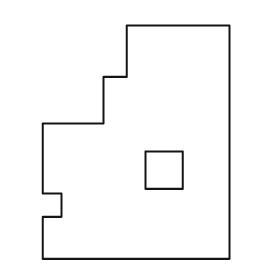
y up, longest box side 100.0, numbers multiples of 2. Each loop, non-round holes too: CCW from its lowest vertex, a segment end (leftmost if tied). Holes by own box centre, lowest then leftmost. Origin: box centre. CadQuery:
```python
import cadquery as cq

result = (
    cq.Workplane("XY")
    .moveTo(-40.0, -50.0)
    .lineTo(40.0, -50.0)
    .lineTo(40.0, 50.0)
    .lineTo(-4.0, 50.0)
    .lineTo(-4.0, 28.0)
    .lineTo(-14.0, 28.0)
    .lineTo(-14.0, 8.0)
    .lineTo(-40.0, 8.0)
    .lineTo(-40.0, -22.0)
    .lineTo(-32.0, -22.0)
    .lineTo(-32.0, -32.0)
    .lineTo(-40.0, -32.0)
    .close()
    .moveTo(4.0, -20.0)
    .lineTo(20.0, -20.0)
    .lineTo(20.0, -4.0)
    .lineTo(4.0, -4.0)
    .close()
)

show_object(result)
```